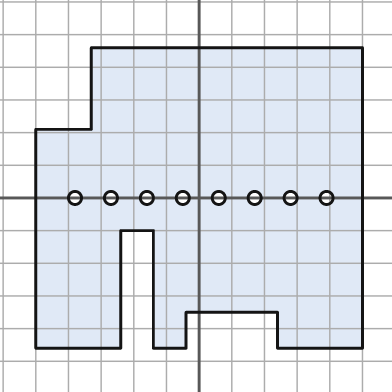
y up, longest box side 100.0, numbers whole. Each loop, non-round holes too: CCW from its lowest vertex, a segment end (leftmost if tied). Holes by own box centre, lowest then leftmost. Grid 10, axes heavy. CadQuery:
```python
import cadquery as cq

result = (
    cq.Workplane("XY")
    .moveTo(-50.0, -46.0)
    .lineTo(-24.0, -46.0)
    .lineTo(-24.0, -10.0)
    .lineTo(-14.0, -10.0)
    .lineTo(-14.0, -46.0)
    .lineTo(-4.0, -46.0)
    .lineTo(-4.0, -35.0)
    .lineTo(24.0, -35.0)
    .lineTo(24.0, -46.0)
    .lineTo(50.0, -46.0)
    .lineTo(50.0, 46.0)
    .lineTo(-33.0, 46.0)
    .lineTo(-33.0, 21.0)
    .lineTo(-50.0, 21.0)
    .close()
    .moveTo(-38.0, 0.0)
    .circle(2.0)
    .moveTo(-27.0, 0.0)
    .circle(2.0)
    .moveTo(-16.0, 0.0)
    .circle(2.0)
    .moveTo(-5.0, 0.0)
    .circle(2.0)
    .moveTo(6.0, 0.0)
    .circle(2.0)
    .moveTo(17.0, 0.0)
    .circle(2.0)
    .moveTo(28.0, 0.0)
    .circle(2.0)
    .moveTo(39.0, 0.0)
    .circle(2.0)
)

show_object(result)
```